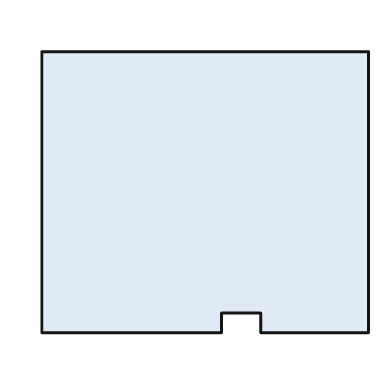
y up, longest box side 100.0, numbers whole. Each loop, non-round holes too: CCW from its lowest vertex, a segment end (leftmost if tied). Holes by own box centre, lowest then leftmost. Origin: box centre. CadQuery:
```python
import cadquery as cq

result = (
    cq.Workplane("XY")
    .moveTo(-50.0, -43.0)
    .lineTo(5.0, -43.0)
    .lineTo(5.0, -37.0)
    .lineTo(17.0, -37.0)
    .lineTo(17.0, -43.0)
    .lineTo(50.0, -43.0)
    .lineTo(50.0, 43.0)
    .lineTo(-50.0, 43.0)
    .close()
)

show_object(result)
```